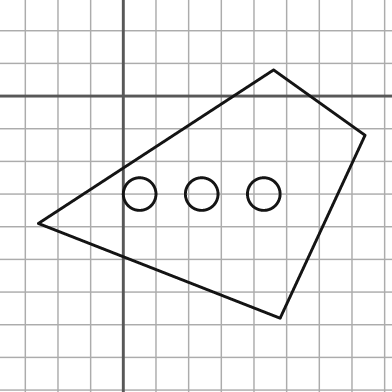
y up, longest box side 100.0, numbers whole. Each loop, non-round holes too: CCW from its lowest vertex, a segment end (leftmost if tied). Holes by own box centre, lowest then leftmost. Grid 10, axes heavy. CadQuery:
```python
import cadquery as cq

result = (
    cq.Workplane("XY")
    .moveTo(48.0, -68.0)
    .lineTo(74.0, -12.0)
    .lineTo(46.0, 8.0)
    .lineTo(-26.0, -39.0)
    .close()
    .moveTo(5.0, -30.0)
    .circle(5.0)
    .moveTo(24.0, -30.0)
    .circle(5.0)
    .moveTo(43.0, -30.0)
    .circle(5.0)
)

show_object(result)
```